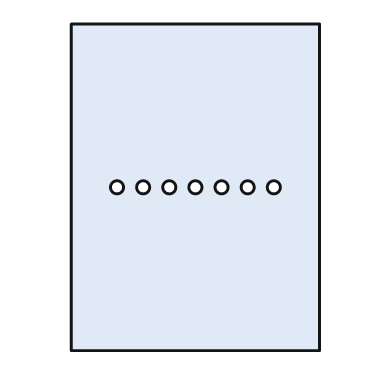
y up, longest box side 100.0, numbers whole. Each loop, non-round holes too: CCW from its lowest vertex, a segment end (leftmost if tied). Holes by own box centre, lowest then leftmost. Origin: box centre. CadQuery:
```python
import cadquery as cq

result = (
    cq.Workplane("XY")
    .moveTo(-38.0, -50.0)
    .lineTo(38.0, -50.0)
    .lineTo(38.0, 50.0)
    .lineTo(-38.0, 50.0)
    .close()
    .moveTo(-24.0, 0.0)
    .circle(2.0)
    .moveTo(-16.0, 0.0)
    .circle(2.0)
    .moveTo(-8.0, 0.0)
    .circle(2.0)
    .moveTo(0.0, 0.0)
    .circle(2.0)
    .moveTo(8.0, 0.0)
    .circle(2.0)
    .moveTo(16.0, 0.0)
    .circle(2.0)
    .moveTo(24.0, 0.0)
    .circle(2.0)
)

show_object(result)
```